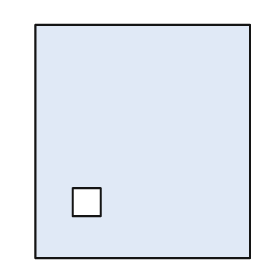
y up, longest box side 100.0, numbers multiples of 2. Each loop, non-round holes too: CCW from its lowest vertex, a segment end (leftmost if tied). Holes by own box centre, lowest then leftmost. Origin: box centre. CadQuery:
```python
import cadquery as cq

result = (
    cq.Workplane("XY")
    .moveTo(-46.0, -50.0)
    .lineTo(46.0, -50.0)
    .lineTo(46.0, 50.0)
    .lineTo(-46.0, 50.0)
    .close()
    .moveTo(-30.0, -32.0)
    .lineTo(-18.0, -32.0)
    .lineTo(-18.0, -20.0)
    .lineTo(-30.0, -20.0)
    .close()
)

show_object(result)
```